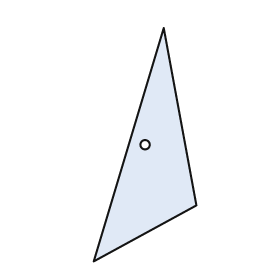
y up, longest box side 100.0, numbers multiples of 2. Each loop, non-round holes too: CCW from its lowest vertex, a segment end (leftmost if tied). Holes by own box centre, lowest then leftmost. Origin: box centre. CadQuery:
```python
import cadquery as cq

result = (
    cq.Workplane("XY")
    .moveTo(-22.0, -50.0)
    .lineTo(22.0, -26.0)
    .lineTo(8.0, 50.0)
    .close()
    .moveTo(0.0, 0.0)
    .circle(2.0)
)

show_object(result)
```